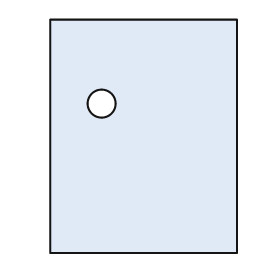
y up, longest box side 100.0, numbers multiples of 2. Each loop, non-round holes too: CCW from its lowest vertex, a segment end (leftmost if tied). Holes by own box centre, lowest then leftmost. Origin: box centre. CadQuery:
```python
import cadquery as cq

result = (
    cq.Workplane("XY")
    .moveTo(-40.0, -50.0)
    .lineTo(40.0, -50.0)
    .lineTo(40.0, 50.0)
    .lineTo(-40.0, 50.0)
    .close()
    .moveTo(-18.0, 14.0)
    .circle(6.0)
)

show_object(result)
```